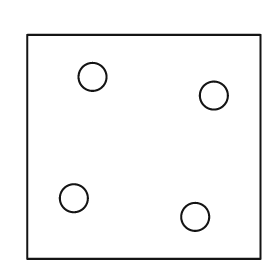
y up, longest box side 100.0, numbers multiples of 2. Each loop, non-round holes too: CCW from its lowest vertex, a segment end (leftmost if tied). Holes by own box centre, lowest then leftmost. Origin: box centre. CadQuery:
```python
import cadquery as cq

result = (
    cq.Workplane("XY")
    .moveTo(-50.0, -48.0)
    .lineTo(50.0, -48.0)
    .lineTo(50.0, 48.0)
    .lineTo(-50.0, 48.0)
    .close()
    .moveTo(22.0, -30.0)
    .circle(6.0)
    .moveTo(-30.0, -22.0)
    .circle(6.0)
    .moveTo(30.0, 22.0)
    .circle(6.0)
    .moveTo(-22.0, 30.0)
    .circle(6.0)
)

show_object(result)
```